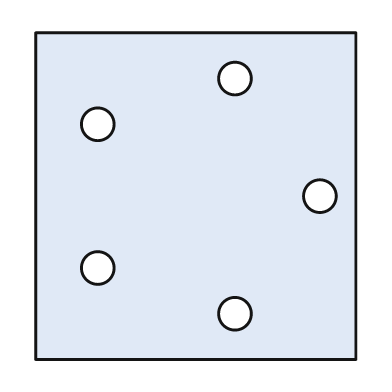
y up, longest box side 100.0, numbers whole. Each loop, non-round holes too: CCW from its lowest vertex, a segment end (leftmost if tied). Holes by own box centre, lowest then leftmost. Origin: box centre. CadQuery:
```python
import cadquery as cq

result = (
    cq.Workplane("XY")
    .moveTo(-49.0, -50.0)
    .lineTo(49.0, -50.0)
    .lineTo(49.0, 50.0)
    .lineTo(-49.0, 50.0)
    .close()
    .moveTo(12.0, -36.0)
    .circle(5.0)
    .moveTo(-30.0, -22.0)
    .circle(5.0)
    .moveTo(38.0, 0.0)
    .circle(5.0)
    .moveTo(-30.0, 22.0)
    .circle(5.0)
    .moveTo(12.0, 36.0)
    .circle(5.0)
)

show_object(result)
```